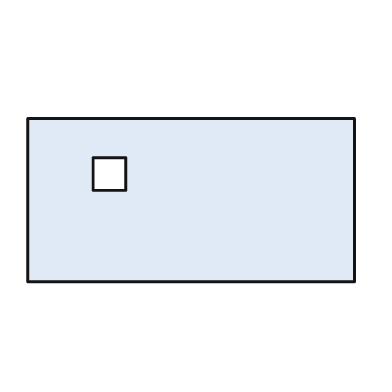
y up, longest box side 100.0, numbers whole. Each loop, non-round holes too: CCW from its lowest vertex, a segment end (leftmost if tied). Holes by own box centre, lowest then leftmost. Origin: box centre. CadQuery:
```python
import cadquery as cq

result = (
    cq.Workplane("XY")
    .moveTo(-50.0, -25.0)
    .lineTo(50.0, -25.0)
    .lineTo(50.0, 25.0)
    .lineTo(-50.0, 25.0)
    .close()
    .moveTo(-30.0, 3.0)
    .lineTo(-20.0, 3.0)
    .lineTo(-20.0, 13.0)
    .lineTo(-30.0, 13.0)
    .close()
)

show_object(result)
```